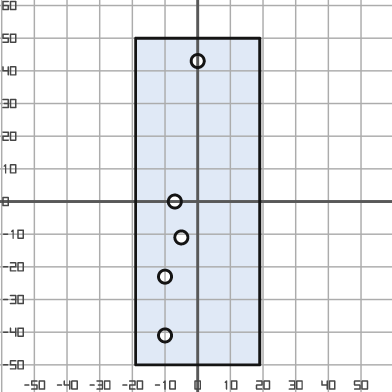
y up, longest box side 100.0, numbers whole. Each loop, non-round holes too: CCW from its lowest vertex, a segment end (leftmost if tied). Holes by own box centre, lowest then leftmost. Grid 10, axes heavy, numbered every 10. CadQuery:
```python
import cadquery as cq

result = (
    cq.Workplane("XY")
    .moveTo(-19.0, -50.0)
    .lineTo(19.0, -50.0)
    .lineTo(19.0, 50.0)
    .lineTo(-19.0, 50.0)
    .close()
    .moveTo(-10.0, -41.0)
    .circle(2.0)
    .moveTo(-10.0, -23.0)
    .circle(2.0)
    .moveTo(-5.0, -11.0)
    .circle(2.0)
    .moveTo(-7.0, 0.0)
    .circle(2.0)
    .moveTo(0.0, 43.0)
    .circle(2.0)
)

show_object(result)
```